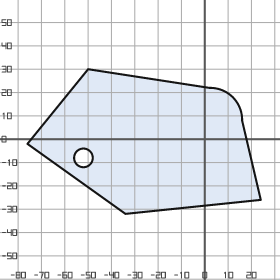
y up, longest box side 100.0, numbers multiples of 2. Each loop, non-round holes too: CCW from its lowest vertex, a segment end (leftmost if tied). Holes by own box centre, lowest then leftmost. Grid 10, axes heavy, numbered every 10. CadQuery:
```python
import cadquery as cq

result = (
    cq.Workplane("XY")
    .moveTo(-34.0, -32.0)
    .lineTo(24.0, -26.0)
    .lineTo(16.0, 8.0)
    .threePointArc((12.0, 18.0), (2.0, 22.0))
    .lineTo(-50.0, 30.0)
    .lineTo(-76.0, -2.0)
    .close()
    .moveTo(-52.0, -8.0)
    .circle(4.0)
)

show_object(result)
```